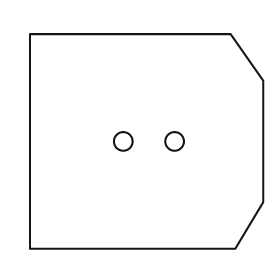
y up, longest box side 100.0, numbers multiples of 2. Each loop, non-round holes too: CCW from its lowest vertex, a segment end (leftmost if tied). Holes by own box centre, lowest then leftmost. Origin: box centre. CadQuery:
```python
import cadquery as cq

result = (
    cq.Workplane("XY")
    .moveTo(-50.0, -46.0)
    .lineTo(38.0, -46.0)
    .lineTo(50.0, -26.0)
    .lineTo(50.0, 26.0)
    .lineTo(36.0, 46.0)
    .lineTo(-50.0, 46.0)
    .close()
    .moveTo(-10.0, 0.0)
    .circle(4.0)
    .moveTo(12.0, 0.0)
    .circle(4.0)
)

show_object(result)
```